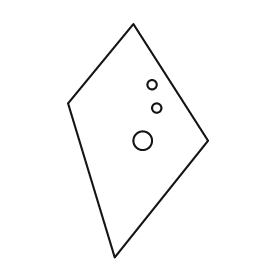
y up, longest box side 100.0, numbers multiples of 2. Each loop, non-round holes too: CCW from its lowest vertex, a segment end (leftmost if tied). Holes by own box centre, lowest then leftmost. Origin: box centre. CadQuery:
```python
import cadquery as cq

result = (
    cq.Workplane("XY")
    .moveTo(-10.0, -50.0)
    .lineTo(30.0, 0.0)
    .lineTo(-2.0, 50.0)
    .lineTo(-30.0, 16.0)
    .close()
    .moveTo(2.0, 0.0)
    .circle(4.0)
    .moveTo(8.0, 14.0)
    .circle(2.0)
    .moveTo(6.0, 24.0)
    .circle(2.0)
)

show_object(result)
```